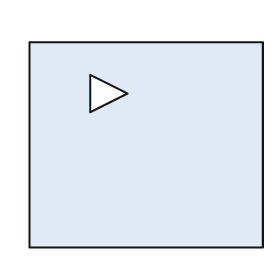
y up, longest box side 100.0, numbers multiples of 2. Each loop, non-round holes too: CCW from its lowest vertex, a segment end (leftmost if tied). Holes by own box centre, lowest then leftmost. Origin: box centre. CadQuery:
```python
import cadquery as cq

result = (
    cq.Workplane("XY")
    .moveTo(-50.0, -44.0)
    .lineTo(50.0, -44.0)
    .lineTo(50.0, 44.0)
    .lineTo(-50.0, 44.0)
    .close()
    .moveTo(-24.0, 14.0)
    .lineTo(-8.0, 22.0)
    .lineTo(-24.0, 30.0)
    .close()
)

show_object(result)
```